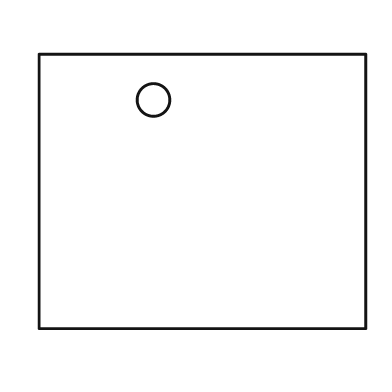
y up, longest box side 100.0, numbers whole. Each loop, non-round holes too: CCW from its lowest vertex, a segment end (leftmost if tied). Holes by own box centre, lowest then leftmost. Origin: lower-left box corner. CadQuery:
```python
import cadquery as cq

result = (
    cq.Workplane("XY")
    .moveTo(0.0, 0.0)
    .lineTo(100.0, 0.0)
    .lineTo(100.0, 84.0)
    .lineTo(0.0, 84.0)
    .close()
    .moveTo(35.0, 70.0)
    .circle(5.0)
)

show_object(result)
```